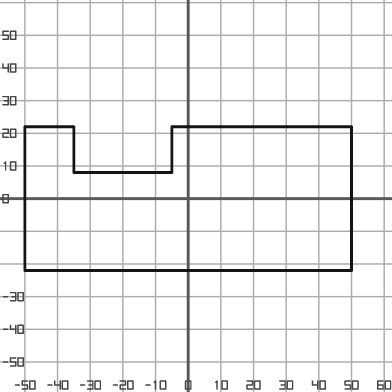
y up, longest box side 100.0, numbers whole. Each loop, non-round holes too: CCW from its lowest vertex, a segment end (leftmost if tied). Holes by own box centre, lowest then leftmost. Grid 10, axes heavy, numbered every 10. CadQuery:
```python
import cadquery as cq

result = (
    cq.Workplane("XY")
    .moveTo(-50.0, -22.0)
    .lineTo(50.0, -22.0)
    .lineTo(50.0, 22.0)
    .lineTo(-5.0, 22.0)
    .lineTo(-5.0, 8.0)
    .lineTo(-35.0, 8.0)
    .lineTo(-35.0, 22.0)
    .lineTo(-50.0, 22.0)
    .close()
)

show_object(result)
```